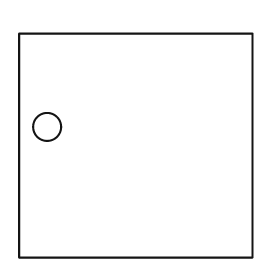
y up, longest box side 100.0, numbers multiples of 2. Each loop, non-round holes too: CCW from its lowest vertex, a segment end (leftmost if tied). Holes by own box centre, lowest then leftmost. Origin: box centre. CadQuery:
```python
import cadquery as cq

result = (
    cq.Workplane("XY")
    .moveTo(-50.0, -48.0)
    .lineTo(50.0, -48.0)
    .lineTo(50.0, 48.0)
    .lineTo(-50.0, 48.0)
    .close()
    .moveTo(-38.0, 8.0)
    .circle(6.0)
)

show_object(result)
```